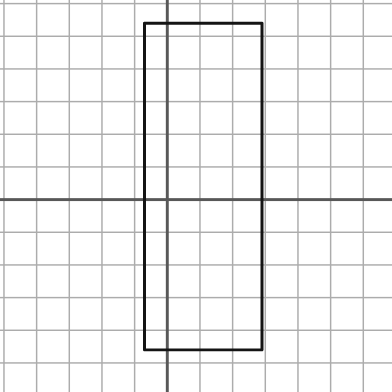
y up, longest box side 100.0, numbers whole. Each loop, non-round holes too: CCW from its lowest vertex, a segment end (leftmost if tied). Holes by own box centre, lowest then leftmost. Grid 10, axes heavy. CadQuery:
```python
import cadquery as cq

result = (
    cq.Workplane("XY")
    .moveTo(-7.0, -46.0)
    .lineTo(29.0, -46.0)
    .lineTo(29.0, 54.0)
    .lineTo(-7.0, 54.0)
    .close()
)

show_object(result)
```